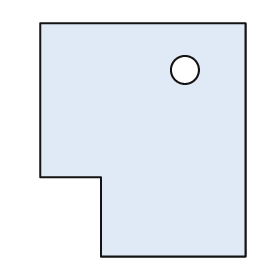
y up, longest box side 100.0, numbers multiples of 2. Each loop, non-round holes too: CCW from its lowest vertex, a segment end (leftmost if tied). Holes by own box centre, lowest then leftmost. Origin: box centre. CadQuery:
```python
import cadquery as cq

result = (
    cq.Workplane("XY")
    .moveTo(-18.0, -50.0)
    .lineTo(44.0, -50.0)
    .lineTo(44.0, 50.0)
    .lineTo(-44.0, 50.0)
    .lineTo(-44.0, -16.0)
    .lineTo(-18.0, -16.0)
    .close()
    .moveTo(18.0, 30.0)
    .circle(6.0)
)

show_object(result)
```